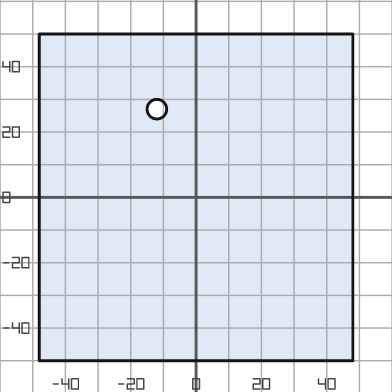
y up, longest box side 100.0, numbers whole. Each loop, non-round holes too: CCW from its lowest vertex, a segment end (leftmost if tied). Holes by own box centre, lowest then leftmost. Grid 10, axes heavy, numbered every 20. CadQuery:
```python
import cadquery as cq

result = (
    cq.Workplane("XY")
    .moveTo(-48.0, -50.0)
    .lineTo(48.0, -50.0)
    .lineTo(48.0, 50.0)
    .lineTo(-48.0, 50.0)
    .close()
    .moveTo(-12.0, 27.0)
    .circle(3.0)
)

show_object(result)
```